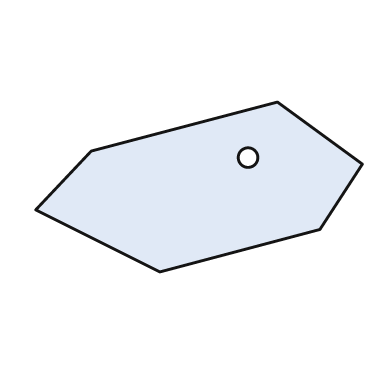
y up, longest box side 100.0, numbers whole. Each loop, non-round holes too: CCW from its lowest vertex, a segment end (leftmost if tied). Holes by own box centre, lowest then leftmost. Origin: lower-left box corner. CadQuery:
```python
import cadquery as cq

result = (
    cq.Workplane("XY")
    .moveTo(38.0, 0.0)
    .lineTo(87.0, 13.0)
    .lineTo(100.0, 33.0)
    .lineTo(74.0, 52.0)
    .lineTo(17.0, 37.0)
    .lineTo(0.0, 19.0)
    .close()
    .moveTo(65.0, 35.0)
    .circle(3.0)
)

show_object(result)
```